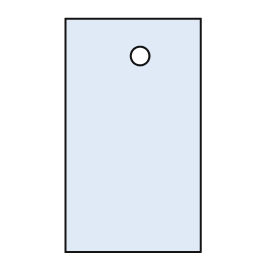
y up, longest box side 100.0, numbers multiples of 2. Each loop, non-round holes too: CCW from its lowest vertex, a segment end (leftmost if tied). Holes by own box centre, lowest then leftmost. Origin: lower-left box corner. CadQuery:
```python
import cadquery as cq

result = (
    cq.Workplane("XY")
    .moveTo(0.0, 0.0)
    .lineTo(58.0, 0.0)
    .lineTo(58.0, 100.0)
    .lineTo(0.0, 100.0)
    .close()
    .moveTo(32.0, 84.0)
    .circle(4.0)
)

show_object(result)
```